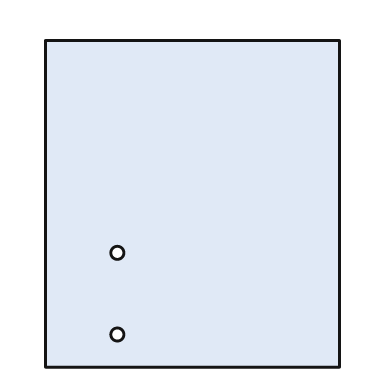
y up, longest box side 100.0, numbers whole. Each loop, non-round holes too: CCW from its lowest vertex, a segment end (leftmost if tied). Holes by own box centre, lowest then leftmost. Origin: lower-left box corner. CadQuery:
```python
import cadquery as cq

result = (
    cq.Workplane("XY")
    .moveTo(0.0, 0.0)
    .lineTo(90.0, 0.0)
    .lineTo(90.0, 100.0)
    .lineTo(0.0, 100.0)
    .close()
    .moveTo(22.0, 10.0)
    .circle(2.0)
    .moveTo(22.0, 35.0)
    .circle(2.0)
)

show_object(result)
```